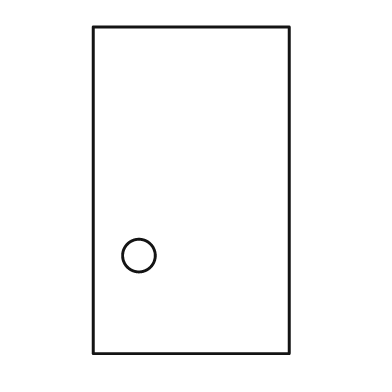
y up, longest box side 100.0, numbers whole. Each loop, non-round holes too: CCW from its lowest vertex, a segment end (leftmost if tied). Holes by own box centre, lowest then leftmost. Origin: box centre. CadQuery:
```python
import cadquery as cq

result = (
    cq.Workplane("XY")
    .moveTo(-30.0, -50.0)
    .lineTo(30.0, -50.0)
    .lineTo(30.0, 50.0)
    .lineTo(-30.0, 50.0)
    .close()
    .moveTo(-16.0, -20.0)
    .circle(5.0)
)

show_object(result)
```